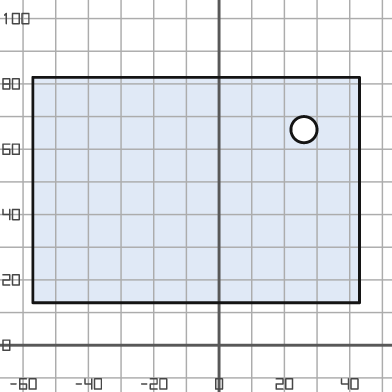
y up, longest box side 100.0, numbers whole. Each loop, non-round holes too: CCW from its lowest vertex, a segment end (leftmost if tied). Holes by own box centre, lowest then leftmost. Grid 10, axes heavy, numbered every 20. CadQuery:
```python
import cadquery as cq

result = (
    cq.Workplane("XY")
    .moveTo(-57.0, 13.0)
    .lineTo(43.0, 13.0)
    .lineTo(43.0, 82.0)
    .lineTo(-57.0, 82.0)
    .close()
    .moveTo(26.0, 66.0)
    .circle(4.0)
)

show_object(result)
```